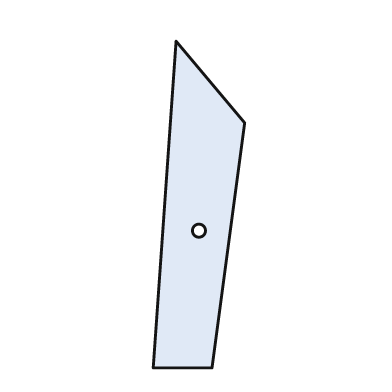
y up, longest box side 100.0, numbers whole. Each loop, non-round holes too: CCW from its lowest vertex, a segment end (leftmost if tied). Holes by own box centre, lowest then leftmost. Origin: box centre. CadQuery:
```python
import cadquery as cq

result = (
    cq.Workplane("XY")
    .moveTo(-14.0, -50.0)
    .lineTo(4.0, -50.0)
    .lineTo(14.0, 25.0)
    .lineTo(-7.0, 50.0)
    .close()
    .moveTo(0.0, -8.0)
    .circle(2.0)
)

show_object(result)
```